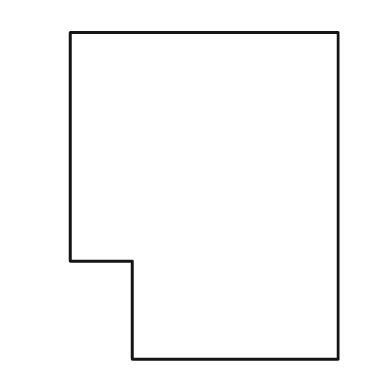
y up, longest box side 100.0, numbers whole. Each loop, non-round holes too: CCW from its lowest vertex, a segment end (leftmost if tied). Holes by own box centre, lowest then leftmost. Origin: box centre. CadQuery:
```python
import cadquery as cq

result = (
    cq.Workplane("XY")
    .moveTo(-22.0, -50.0)
    .lineTo(41.0, -50.0)
    .lineTo(41.0, 50.0)
    .lineTo(-41.0, 50.0)
    .lineTo(-41.0, -20.0)
    .lineTo(-22.0, -20.0)
    .close()
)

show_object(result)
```